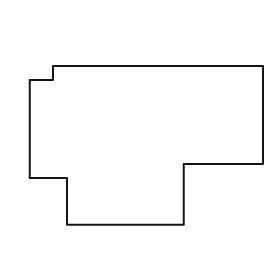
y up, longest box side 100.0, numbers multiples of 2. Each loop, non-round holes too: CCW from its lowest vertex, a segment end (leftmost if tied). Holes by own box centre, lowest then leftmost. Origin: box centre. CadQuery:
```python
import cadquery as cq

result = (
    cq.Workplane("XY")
    .moveTo(-34.0, -34.0)
    .lineTo(16.0, -34.0)
    .lineTo(16.0, -8.0)
    .lineTo(50.0, -8.0)
    .lineTo(50.0, 34.0)
    .lineTo(-40.0, 34.0)
    .lineTo(-40.0, 28.0)
    .lineTo(-50.0, 28.0)
    .lineTo(-50.0, -14.0)
    .lineTo(-34.0, -14.0)
    .close()
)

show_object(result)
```